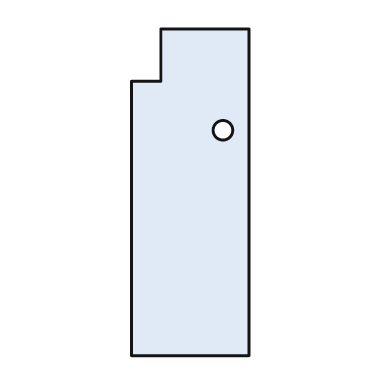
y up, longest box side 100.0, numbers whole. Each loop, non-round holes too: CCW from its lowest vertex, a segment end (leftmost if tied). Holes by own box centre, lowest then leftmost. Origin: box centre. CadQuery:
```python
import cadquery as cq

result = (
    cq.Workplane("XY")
    .moveTo(-18.0, -50.0)
    .lineTo(18.0, -50.0)
    .lineTo(18.0, 50.0)
    .lineTo(-9.0, 50.0)
    .lineTo(-9.0, 34.0)
    .lineTo(-18.0, 34.0)
    .close()
    .moveTo(10.0, 19.0)
    .circle(3.0)
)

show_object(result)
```